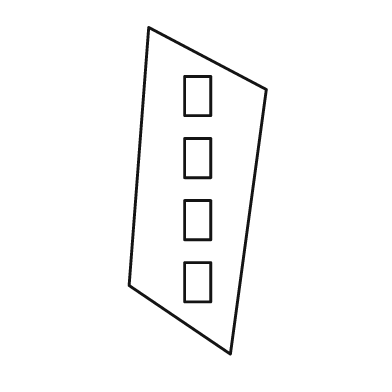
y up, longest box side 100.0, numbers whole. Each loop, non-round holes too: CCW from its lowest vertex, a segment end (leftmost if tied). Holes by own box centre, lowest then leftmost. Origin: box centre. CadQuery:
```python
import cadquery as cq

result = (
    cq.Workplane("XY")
    .moveTo(10.0, -50.0)
    .lineTo(21.0, 31.0)
    .lineTo(-15.0, 50.0)
    .lineTo(-21.0, -29.0)
    .close()
    .moveTo(-4.0, -34.0)
    .lineTo(4.0, -34.0)
    .lineTo(4.0, -22.0)
    .lineTo(-4.0, -22.0)
    .close()
    .moveTo(-4.0, -15.0)
    .lineTo(4.0, -15.0)
    .lineTo(4.0, -3.0)
    .lineTo(-4.0, -3.0)
    .close()
    .moveTo(-4.0, 4.0)
    .lineTo(4.0, 4.0)
    .lineTo(4.0, 16.0)
    .lineTo(-4.0, 16.0)
    .close()
    .moveTo(-4.0, 23.0)
    .lineTo(4.0, 23.0)
    .lineTo(4.0, 35.0)
    .lineTo(-4.0, 35.0)
    .close()
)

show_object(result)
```